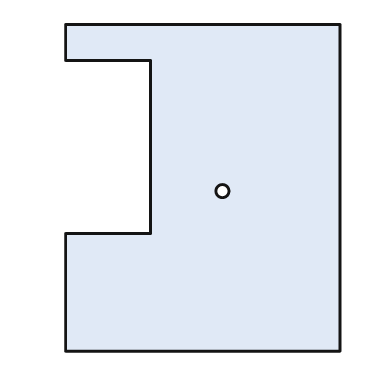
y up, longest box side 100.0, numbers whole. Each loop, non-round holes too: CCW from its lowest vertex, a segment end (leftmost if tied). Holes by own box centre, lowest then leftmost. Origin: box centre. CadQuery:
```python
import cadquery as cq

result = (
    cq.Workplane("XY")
    .moveTo(-42.0, -50.0)
    .lineTo(42.0, -50.0)
    .lineTo(42.0, 50.0)
    .lineTo(-42.0, 50.0)
    .lineTo(-42.0, 39.0)
    .lineTo(-16.0, 39.0)
    .lineTo(-16.0, -14.0)
    .lineTo(-42.0, -14.0)
    .close()
    .moveTo(6.0, -1.0)
    .circle(2.0)
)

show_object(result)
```